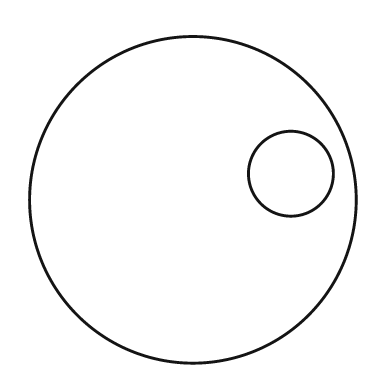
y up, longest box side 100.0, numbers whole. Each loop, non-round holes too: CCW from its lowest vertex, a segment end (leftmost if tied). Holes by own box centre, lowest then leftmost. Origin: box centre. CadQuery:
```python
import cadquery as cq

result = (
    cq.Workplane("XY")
    .moveTo(0.0, 0.0)
    .circle(50.0)
    .moveTo(30.0, 8.0)
    .circle(13.0)
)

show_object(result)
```